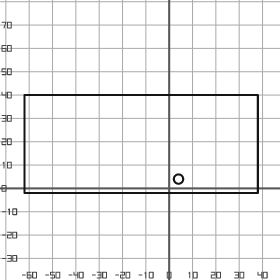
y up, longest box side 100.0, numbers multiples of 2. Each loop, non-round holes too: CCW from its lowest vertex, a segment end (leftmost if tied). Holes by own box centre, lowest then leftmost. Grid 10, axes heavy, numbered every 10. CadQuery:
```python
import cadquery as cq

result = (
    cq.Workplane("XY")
    .moveTo(-62.0, -2.0)
    .lineTo(38.0, -2.0)
    .lineTo(38.0, 40.0)
    .lineTo(-62.0, 40.0)
    .close()
    .moveTo(4.0, 4.0)
    .circle(2.0)
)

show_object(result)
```